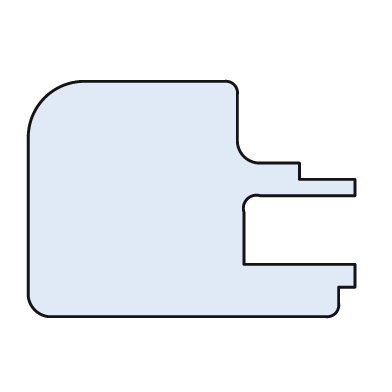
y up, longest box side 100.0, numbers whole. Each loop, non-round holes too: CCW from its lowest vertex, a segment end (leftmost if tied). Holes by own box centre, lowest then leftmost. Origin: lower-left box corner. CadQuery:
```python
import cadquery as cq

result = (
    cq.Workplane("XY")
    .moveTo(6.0, 0.0)
    .lineTo(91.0, 0.0)
    .threePointArc((94.0, 1.0), (95.0, 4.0))
    .lineTo(95.0, 9.0)
    .lineTo(100.0, 9.0)
    .lineTo(100.0, 16.0)
    .lineTo(66.0, 16.0)
    .lineTo(66.0, 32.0)
    .threePointArc((67.0, 36.0), (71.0, 37.0))
    .lineTo(100.0, 37.0)
    .lineTo(100.0, 42.0)
    .lineTo(83.0, 42.0)
    .lineTo(83.0, 47.0)
    .lineTo(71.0, 47.0)
    .threePointArc((66.0, 49.0), (64.0, 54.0))
    .lineTo(64.0, 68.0)
    .threePointArc((63.0, 71.0), (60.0, 72.0))
    .lineTo(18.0, 72.0)
    .threePointArc((5.0, 67.0), (0.0, 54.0))
    .lineTo(0.0, 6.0)
    .threePointArc((2.0, 2.0), (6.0, 0.0))
    .close()
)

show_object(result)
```